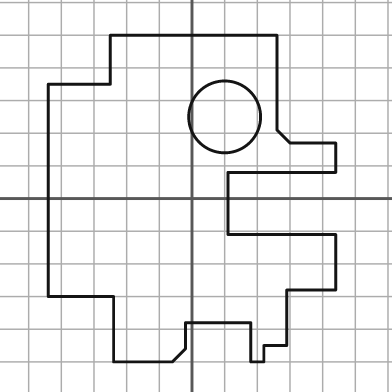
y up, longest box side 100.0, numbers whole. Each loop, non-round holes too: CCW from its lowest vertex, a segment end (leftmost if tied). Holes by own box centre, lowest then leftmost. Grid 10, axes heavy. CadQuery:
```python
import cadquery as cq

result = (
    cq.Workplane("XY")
    .moveTo(-24.0, -50.0)
    .lineTo(-6.0, -50.0)
    .lineTo(-2.0, -46.0)
    .lineTo(-2.0, -38.0)
    .lineTo(18.0, -38.0)
    .lineTo(18.0, -50.0)
    .lineTo(22.0, -50.0)
    .lineTo(22.0, -45.0)
    .lineTo(29.0, -45.0)
    .lineTo(29.0, -28.0)
    .lineTo(44.0, -28.0)
    .lineTo(44.0, -11.0)
    .lineTo(11.0, -11.0)
    .lineTo(11.0, 8.0)
    .lineTo(44.0, 8.0)
    .lineTo(44.0, 17.0)
    .lineTo(30.0, 17.0)
    .lineTo(26.0, 21.0)
    .lineTo(26.0, 50.0)
    .lineTo(-25.0, 50.0)
    .lineTo(-25.0, 35.0)
    .lineTo(-44.0, 35.0)
    .lineTo(-44.0, -30.0)
    .lineTo(-24.0, -30.0)
    .close()
    .moveTo(10.0, 25.0)
    .circle(11.0)
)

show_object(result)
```